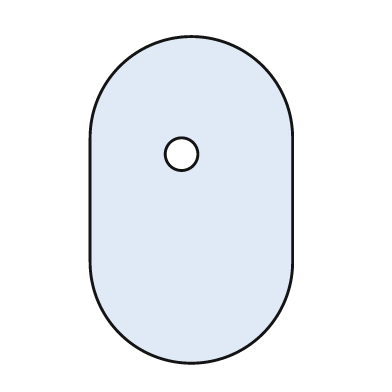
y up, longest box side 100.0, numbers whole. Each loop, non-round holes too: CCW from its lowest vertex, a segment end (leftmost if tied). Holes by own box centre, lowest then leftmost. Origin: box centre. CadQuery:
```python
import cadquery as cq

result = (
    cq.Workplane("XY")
    .moveTo(-31.0, -19.0)
    .threePointArc((0.0, -50.0), (31.0, -19.0))
    .lineTo(31.0, 19.0)
    .threePointArc((0.0, 50.0), (-31.0, 19.0))
    .close()
    .moveTo(-3.0, 14.0)
    .circle(5.0)
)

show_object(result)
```